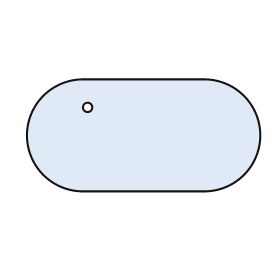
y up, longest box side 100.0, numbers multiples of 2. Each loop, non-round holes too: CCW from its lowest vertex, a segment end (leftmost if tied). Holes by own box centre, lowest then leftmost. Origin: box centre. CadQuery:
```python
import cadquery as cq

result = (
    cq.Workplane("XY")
    .moveTo(-26.0, -24.0)
    .lineTo(26.0, -24.0)
    .threePointArc((50.0, 0.0), (26.0, 24.0))
    .lineTo(-26.0, 24.0)
    .threePointArc((-50.0, 0.0), (-26.0, -24.0))
    .close()
    .moveTo(-24.0, 12.0)
    .circle(2.0)
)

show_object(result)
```